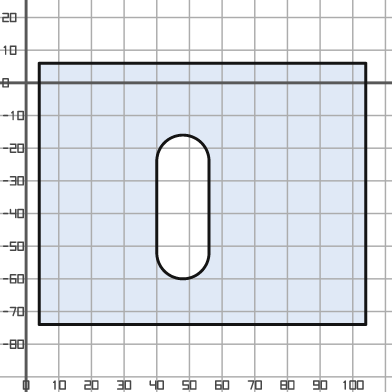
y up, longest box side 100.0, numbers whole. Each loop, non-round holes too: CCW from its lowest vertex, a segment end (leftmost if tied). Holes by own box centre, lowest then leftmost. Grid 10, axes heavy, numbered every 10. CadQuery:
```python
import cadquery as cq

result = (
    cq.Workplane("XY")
    .moveTo(4.0, -74.0)
    .lineTo(104.0, -74.0)
    .lineTo(104.0, 6.0)
    .lineTo(4.0, 6.0)
    .close()
    .moveTo(40.0, -52.0)
    .threePointArc((48.0, -60.0), (56.0, -52.0))
    .lineTo(56.0, -24.0)
    .threePointArc((48.0, -16.0), (40.0, -24.0))
    .close()
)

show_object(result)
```